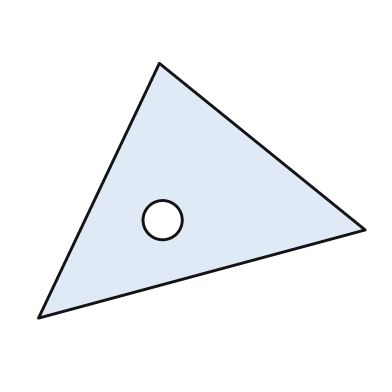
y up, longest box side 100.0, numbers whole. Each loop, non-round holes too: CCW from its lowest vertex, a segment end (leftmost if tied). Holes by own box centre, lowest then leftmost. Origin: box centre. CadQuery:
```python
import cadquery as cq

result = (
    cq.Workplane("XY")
    .moveTo(-50.0, -39.0)
    .lineTo(50.0, -12.0)
    .lineTo(-13.0, 39.0)
    .close()
    .moveTo(-12.0, -9.0)
    .circle(6.0)
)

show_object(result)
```